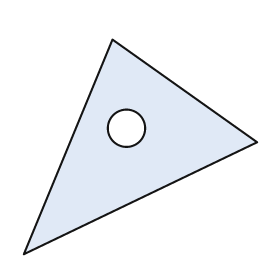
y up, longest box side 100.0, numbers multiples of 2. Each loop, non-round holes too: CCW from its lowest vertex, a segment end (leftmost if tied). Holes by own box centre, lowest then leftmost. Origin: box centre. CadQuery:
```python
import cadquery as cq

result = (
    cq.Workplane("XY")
    .moveTo(-50.0, -46.0)
    .lineTo(50.0, 2.0)
    .lineTo(-12.0, 46.0)
    .close()
    .moveTo(-6.0, 8.0)
    .circle(8.0)
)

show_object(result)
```